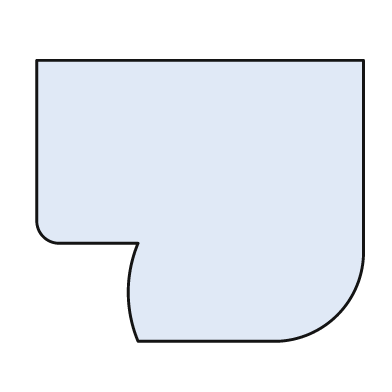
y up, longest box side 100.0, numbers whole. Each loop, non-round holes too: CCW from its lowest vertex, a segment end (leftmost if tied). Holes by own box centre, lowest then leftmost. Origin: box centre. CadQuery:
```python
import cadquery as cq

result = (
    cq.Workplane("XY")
    .moveTo(-19.0, -43.0)
    .lineTo(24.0, -43.0)
    .threePointArc((42.0, -35.0), (50.0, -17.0))
    .lineTo(50.0, 43.0)
    .lineTo(-50.0, 43.0)
    .lineTo(-50.0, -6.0)
    .threePointArc((-48.0, -11.0), (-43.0, -13.0))
    .lineTo(-19.0, -13.0)
    .threePointArc((-22.0, -28.0), (-19.0, -43.0))
    .close()
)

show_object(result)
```